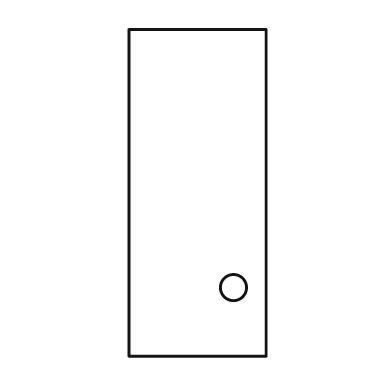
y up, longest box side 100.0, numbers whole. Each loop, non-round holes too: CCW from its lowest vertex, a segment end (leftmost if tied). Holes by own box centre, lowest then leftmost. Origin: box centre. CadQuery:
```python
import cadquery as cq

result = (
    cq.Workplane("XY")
    .moveTo(-21.0, -50.0)
    .lineTo(21.0, -50.0)
    .lineTo(21.0, 50.0)
    .lineTo(-21.0, 50.0)
    .close()
    .moveTo(11.0, -29.0)
    .circle(4.0)
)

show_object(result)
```